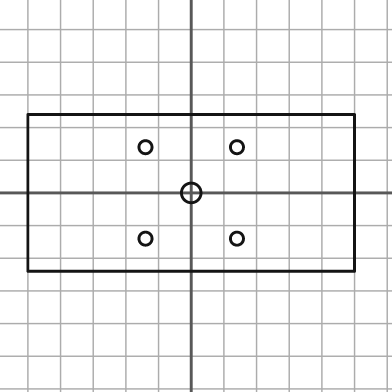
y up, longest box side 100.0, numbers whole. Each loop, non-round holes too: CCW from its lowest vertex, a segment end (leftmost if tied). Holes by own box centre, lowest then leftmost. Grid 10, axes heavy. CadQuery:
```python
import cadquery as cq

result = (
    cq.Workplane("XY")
    .moveTo(-50.0, -24.0)
    .lineTo(50.0, -24.0)
    .lineTo(50.0, 24.0)
    .lineTo(-50.0, 24.0)
    .close()
    .moveTo(-14.0, -14.0)
    .circle(2.0)
    .moveTo(14.0, -14.0)
    .circle(2.0)
    .moveTo(0.0, 0.0)
    .circle(3.0)
    .moveTo(-14.0, 14.0)
    .circle(2.0)
    .moveTo(14.0, 14.0)
    .circle(2.0)
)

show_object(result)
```